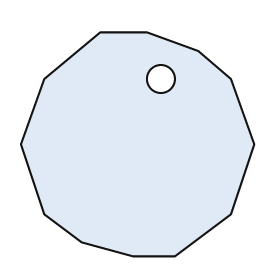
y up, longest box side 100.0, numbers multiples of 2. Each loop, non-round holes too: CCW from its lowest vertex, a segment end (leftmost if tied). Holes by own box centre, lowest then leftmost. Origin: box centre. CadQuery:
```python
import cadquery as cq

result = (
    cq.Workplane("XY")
    .moveTo(-2.0, -48.0)
    .lineTo(16.0, -48.0)
    .lineTo(40.0, -30.0)
    .lineTo(50.0, 0.0)
    .lineTo(40.0, 28.0)
    .lineTo(26.0, 40.0)
    .lineTo(4.0, 48.0)
    .lineTo(-16.0, 48.0)
    .lineTo(-40.0, 28.0)
    .lineTo(-50.0, 0.0)
    .lineTo(-40.0, -30.0)
    .lineTo(-24.0, -42.0)
    .close()
    .moveTo(10.0, 28.0)
    .circle(6.0)
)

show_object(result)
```